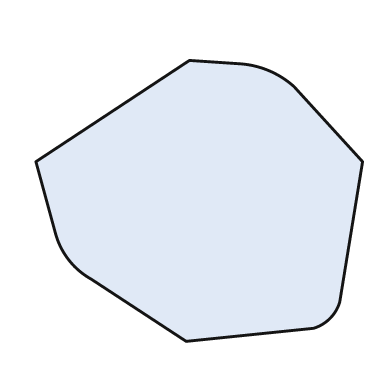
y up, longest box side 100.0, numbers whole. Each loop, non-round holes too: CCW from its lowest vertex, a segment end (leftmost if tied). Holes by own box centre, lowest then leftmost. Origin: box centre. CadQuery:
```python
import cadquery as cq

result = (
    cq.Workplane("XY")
    .moveTo(-4.0, -43.0)
    .lineTo(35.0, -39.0)
    .threePointArc((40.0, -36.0), (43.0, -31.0))
    .lineTo(50.0, 12.0)
    .lineTo(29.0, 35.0)
    .threePointArc((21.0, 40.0), (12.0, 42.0))
    .lineTo(-3.0, 43.0)
    .lineTo(-50.0, 12.0)
    .lineTo(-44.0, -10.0)
    .threePointArc((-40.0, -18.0), (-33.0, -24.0))
    .close()
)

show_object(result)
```